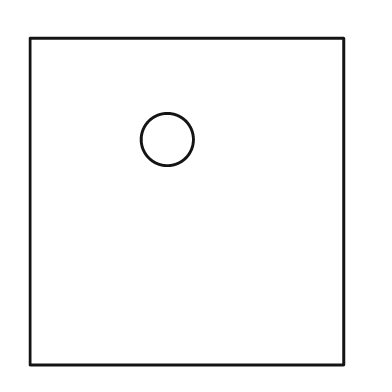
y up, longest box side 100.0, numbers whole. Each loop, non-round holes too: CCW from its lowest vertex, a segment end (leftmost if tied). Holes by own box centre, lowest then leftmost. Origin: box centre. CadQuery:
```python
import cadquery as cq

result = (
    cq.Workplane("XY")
    .moveTo(-48.0, -50.0)
    .lineTo(48.0, -50.0)
    .lineTo(48.0, 50.0)
    .lineTo(-48.0, 50.0)
    .close()
    .moveTo(-6.0, 19.0)
    .circle(8.0)
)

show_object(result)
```